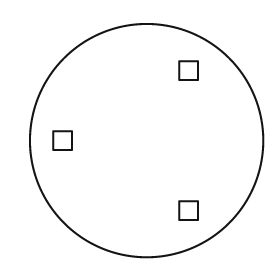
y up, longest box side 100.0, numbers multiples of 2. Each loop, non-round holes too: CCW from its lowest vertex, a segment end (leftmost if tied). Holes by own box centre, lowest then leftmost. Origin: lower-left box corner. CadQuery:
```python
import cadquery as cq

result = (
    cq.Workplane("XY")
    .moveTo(50.0, 50.0)
    .circle(50.0)
    .moveTo(64.0, 16.0)
    .lineTo(72.0, 16.0)
    .lineTo(72.0, 24.0)
    .lineTo(64.0, 24.0)
    .close()
    .moveTo(10.0, 46.0)
    .lineTo(18.0, 46.0)
    .lineTo(18.0, 54.0)
    .lineTo(10.0, 54.0)
    .close()
    .moveTo(64.0, 76.0)
    .lineTo(72.0, 76.0)
    .lineTo(72.0, 84.0)
    .lineTo(64.0, 84.0)
    .close()
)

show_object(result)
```